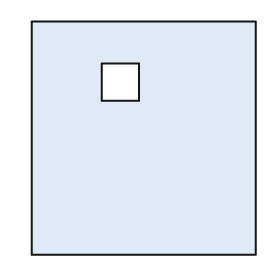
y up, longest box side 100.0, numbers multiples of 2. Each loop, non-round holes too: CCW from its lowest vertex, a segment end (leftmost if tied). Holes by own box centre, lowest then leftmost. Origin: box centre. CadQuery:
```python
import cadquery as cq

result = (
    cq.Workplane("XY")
    .moveTo(-48.0, -50.0)
    .lineTo(48.0, -50.0)
    .lineTo(48.0, 50.0)
    .lineTo(-48.0, 50.0)
    .close()
    .moveTo(-18.0, 16.0)
    .lineTo(-2.0, 16.0)
    .lineTo(-2.0, 32.0)
    .lineTo(-18.0, 32.0)
    .close()
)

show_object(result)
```